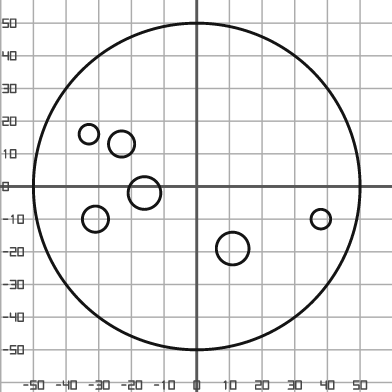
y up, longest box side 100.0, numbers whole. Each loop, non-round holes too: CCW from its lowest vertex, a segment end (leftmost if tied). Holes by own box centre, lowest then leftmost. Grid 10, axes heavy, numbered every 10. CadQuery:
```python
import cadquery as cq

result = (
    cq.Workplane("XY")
    .moveTo(0.0, 0.0)
    .circle(50.0)
    .moveTo(11.0, -19.0)
    .circle(5.0)
    .moveTo(-31.0, -10.0)
    .circle(4.0)
    .moveTo(38.0, -10.0)
    .circle(3.0)
    .moveTo(-16.0, -2.0)
    .circle(5.0)
    .moveTo(-23.0, 13.0)
    .circle(4.0)
    .moveTo(-33.0, 16.0)
    .circle(3.0)
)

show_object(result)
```